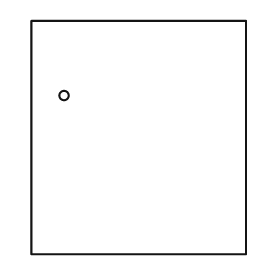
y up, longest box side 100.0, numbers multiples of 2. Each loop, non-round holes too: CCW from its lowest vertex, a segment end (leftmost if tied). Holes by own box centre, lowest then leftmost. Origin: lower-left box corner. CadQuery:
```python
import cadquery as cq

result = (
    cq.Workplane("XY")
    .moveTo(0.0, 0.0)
    .lineTo(92.0, 0.0)
    .lineTo(92.0, 100.0)
    .lineTo(0.0, 100.0)
    .close()
    .moveTo(14.0, 68.0)
    .circle(2.0)
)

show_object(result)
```